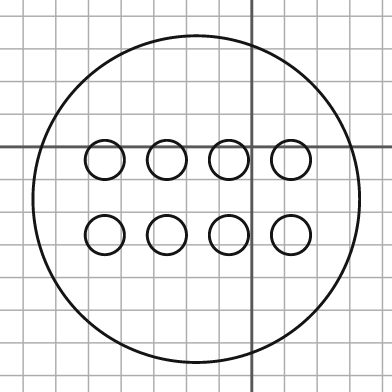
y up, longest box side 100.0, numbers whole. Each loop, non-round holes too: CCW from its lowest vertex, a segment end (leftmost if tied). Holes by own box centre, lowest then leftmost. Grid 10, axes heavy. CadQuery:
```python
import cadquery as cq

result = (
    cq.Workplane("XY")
    .moveTo(-17.0, -16.0)
    .circle(50.0)
    .moveTo(-45.0, -27.0)
    .circle(6.0)
    .moveTo(-26.0, -27.0)
    .circle(6.0)
    .moveTo(-7.0, -27.0)
    .circle(6.0)
    .moveTo(12.0, -27.0)
    .circle(6.0)
    .moveTo(-45.0, -4.0)
    .circle(6.0)
    .moveTo(-26.0, -4.0)
    .circle(6.0)
    .moveTo(-7.0, -4.0)
    .circle(6.0)
    .moveTo(12.0, -4.0)
    .circle(6.0)
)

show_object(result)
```